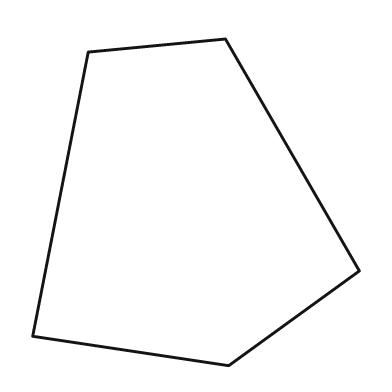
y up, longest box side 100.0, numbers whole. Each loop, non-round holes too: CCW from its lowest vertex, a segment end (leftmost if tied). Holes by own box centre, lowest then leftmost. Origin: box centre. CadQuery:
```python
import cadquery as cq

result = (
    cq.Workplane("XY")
    .moveTo(10.0, -50.0)
    .lineTo(50.0, -21.0)
    .lineTo(9.0, 50.0)
    .lineTo(-33.0, 46.0)
    .lineTo(-50.0, -41.0)
    .close()
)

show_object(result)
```